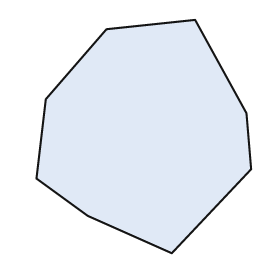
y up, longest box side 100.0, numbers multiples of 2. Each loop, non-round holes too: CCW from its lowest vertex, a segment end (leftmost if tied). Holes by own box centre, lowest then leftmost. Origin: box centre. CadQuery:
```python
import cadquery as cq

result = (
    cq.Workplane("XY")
    .moveTo(12.0, -50.0)
    .lineTo(46.0, -14.0)
    .lineTo(44.0, 10.0)
    .lineTo(22.0, 50.0)
    .lineTo(-16.0, 46.0)
    .lineTo(-42.0, 16.0)
    .lineTo(-46.0, -18.0)
    .lineTo(-24.0, -34.0)
    .close()
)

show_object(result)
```